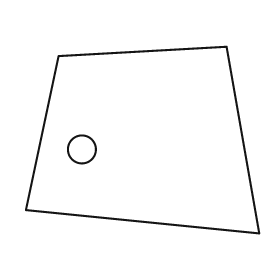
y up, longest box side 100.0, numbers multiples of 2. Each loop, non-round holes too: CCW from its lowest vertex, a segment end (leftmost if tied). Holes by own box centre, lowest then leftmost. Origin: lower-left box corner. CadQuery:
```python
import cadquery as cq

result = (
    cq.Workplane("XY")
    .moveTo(100.0, 0.0)
    .lineTo(86.0, 80.0)
    .lineTo(14.0, 76.0)
    .lineTo(0.0, 10.0)
    .close()
    .moveTo(24.0, 36.0)
    .circle(6.0)
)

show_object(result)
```